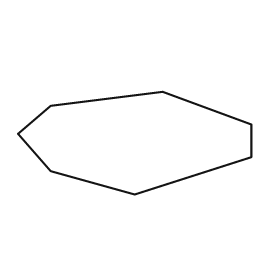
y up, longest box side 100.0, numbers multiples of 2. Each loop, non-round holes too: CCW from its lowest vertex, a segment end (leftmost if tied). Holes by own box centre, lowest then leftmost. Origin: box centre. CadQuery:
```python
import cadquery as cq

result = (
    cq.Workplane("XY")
    .moveTo(0.0, -22.0)
    .lineTo(50.0, -6.0)
    .lineTo(50.0, 8.0)
    .lineTo(12.0, 22.0)
    .lineTo(-36.0, 16.0)
    .lineTo(-50.0, 4.0)
    .lineTo(-36.0, -12.0)
    .close()
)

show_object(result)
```